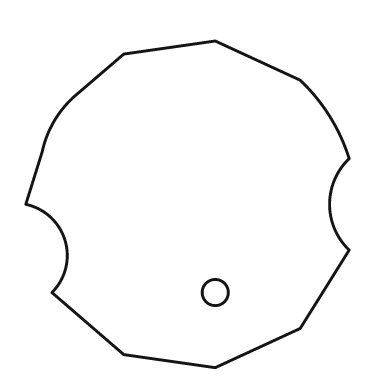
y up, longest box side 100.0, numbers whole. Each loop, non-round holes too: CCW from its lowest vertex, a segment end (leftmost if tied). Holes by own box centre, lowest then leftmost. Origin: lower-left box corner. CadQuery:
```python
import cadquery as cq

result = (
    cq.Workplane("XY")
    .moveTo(58.0, 0.0)
    .lineTo(84.0, 12.0)
    .lineTo(99.0, 36.0)
    .threePointArc((93.0, 50.0), (99.0, 64.0))
    .threePointArc((93.0, 77.0), (84.0, 88.0))
    .lineTo(58.0, 100.0)
    .lineTo(30.0, 96.0)
    .lineTo(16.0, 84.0)
    .threePointArc((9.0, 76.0), (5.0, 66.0))
    .lineTo(0.0, 50.0)
    .threePointArc((12.0, 39.0), (8.0, 23.0))
    .lineTo(30.0, 4.0)
    .close()
    .moveTo(58.0, 23.0)
    .circle(4.0)
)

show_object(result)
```